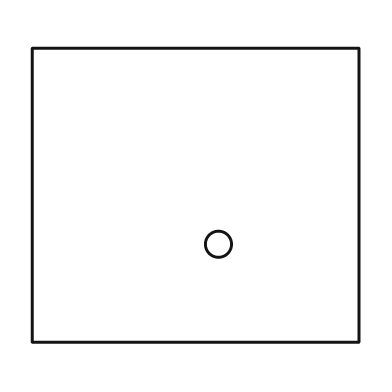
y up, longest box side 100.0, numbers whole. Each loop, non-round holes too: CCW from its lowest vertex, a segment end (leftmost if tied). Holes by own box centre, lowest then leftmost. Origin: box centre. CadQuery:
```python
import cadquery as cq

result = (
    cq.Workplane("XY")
    .moveTo(-50.0, -45.0)
    .lineTo(50.0, -45.0)
    .lineTo(50.0, 45.0)
    .lineTo(-50.0, 45.0)
    .close()
    .moveTo(7.0, -15.0)
    .circle(4.0)
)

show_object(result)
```